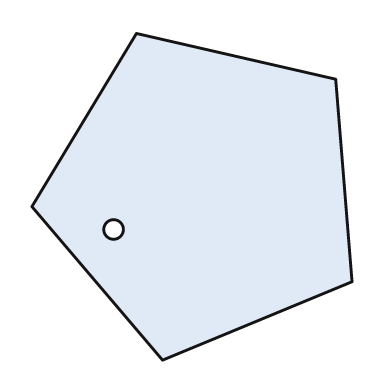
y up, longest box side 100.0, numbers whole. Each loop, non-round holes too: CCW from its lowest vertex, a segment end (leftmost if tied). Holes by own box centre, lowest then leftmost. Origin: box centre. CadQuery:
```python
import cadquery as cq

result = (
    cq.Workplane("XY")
    .moveTo(-9.0, -50.0)
    .lineTo(49.0, -26.0)
    .lineTo(44.0, 36.0)
    .lineTo(-17.0, 50.0)
    .lineTo(-49.0, -3.0)
    .close()
    .moveTo(-24.0, -10.0)
    .circle(3.0)
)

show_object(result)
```